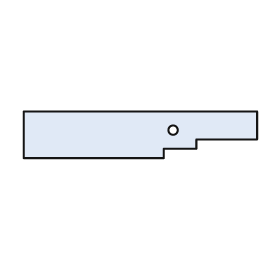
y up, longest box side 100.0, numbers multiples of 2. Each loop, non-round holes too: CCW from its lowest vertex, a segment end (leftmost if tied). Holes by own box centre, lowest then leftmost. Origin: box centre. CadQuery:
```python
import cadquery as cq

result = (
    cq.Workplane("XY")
    .moveTo(-50.0, -10.0)
    .lineTo(10.0, -10.0)
    .lineTo(10.0, -6.0)
    .lineTo(24.0, -6.0)
    .lineTo(24.0, -2.0)
    .lineTo(50.0, -2.0)
    .lineTo(50.0, 10.0)
    .lineTo(-50.0, 10.0)
    .close()
    .moveTo(14.0, 2.0)
    .circle(2.0)
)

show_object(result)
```